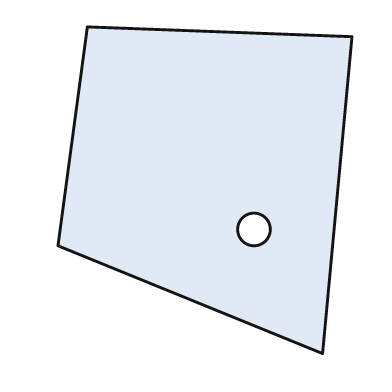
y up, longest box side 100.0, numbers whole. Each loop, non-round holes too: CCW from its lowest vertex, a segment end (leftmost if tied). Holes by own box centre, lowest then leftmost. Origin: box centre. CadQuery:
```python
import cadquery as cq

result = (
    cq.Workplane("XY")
    .moveTo(36.0, -50.0)
    .lineTo(45.0, 47.0)
    .lineTo(-36.0, 50.0)
    .lineTo(-45.0, -17.0)
    .close()
    .moveTo(15.0, -12.0)
    .circle(5.0)
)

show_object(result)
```